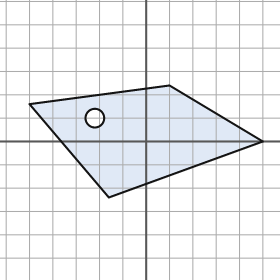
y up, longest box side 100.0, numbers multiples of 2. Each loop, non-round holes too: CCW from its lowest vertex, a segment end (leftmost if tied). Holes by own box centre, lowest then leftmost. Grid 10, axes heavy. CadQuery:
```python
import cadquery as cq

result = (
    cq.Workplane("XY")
    .moveTo(-16.0, -24.0)
    .lineTo(50.0, 0.0)
    .lineTo(10.0, 24.0)
    .lineTo(-50.0, 16.0)
    .close()
    .moveTo(-22.0, 10.0)
    .circle(4.0)
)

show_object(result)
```